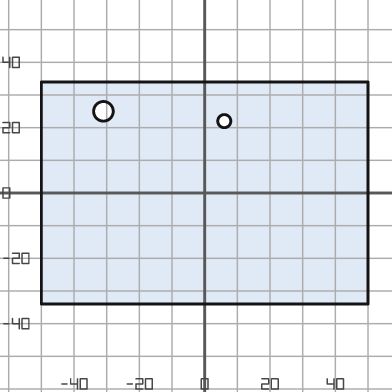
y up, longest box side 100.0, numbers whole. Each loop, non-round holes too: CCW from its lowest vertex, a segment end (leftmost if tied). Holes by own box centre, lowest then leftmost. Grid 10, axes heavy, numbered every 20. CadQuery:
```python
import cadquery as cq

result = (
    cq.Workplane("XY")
    .moveTo(-50.0, -34.0)
    .lineTo(50.0, -34.0)
    .lineTo(50.0, 34.0)
    .lineTo(-50.0, 34.0)
    .close()
    .moveTo(6.0, 22.0)
    .circle(2.0)
    .moveTo(-31.0, 25.0)
    .circle(3.0)
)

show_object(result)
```